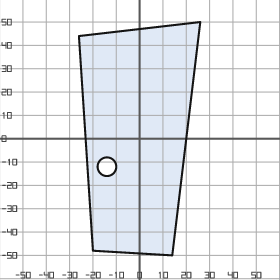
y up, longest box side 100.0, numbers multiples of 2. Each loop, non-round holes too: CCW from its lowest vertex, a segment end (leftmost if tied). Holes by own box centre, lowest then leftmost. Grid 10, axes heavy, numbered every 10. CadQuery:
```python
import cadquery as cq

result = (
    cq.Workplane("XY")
    .moveTo(14.0, -50.0)
    .lineTo(26.0, 50.0)
    .lineTo(-26.0, 44.0)
    .lineTo(-20.0, -48.0)
    .close()
    .moveTo(-14.0, -12.0)
    .circle(4.0)
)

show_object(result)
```